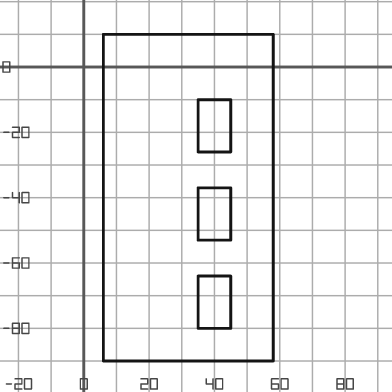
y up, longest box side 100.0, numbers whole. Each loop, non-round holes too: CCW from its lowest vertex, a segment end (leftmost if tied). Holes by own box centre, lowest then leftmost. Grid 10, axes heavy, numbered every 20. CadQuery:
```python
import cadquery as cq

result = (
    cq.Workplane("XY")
    .moveTo(6.0, -90.0)
    .lineTo(58.0, -90.0)
    .lineTo(58.0, 10.0)
    .lineTo(6.0, 10.0)
    .close()
    .moveTo(35.0, -80.0)
    .lineTo(45.0, -80.0)
    .lineTo(45.0, -64.0)
    .lineTo(35.0, -64.0)
    .close()
    .moveTo(35.0, -53.0)
    .lineTo(45.0, -53.0)
    .lineTo(45.0, -37.0)
    .lineTo(35.0, -37.0)
    .close()
    .moveTo(35.0, -26.0)
    .lineTo(45.0, -26.0)
    .lineTo(45.0, -10.0)
    .lineTo(35.0, -10.0)
    .close()
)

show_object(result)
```